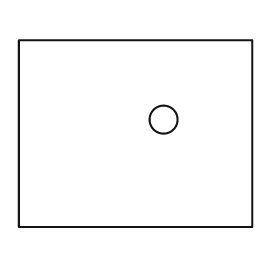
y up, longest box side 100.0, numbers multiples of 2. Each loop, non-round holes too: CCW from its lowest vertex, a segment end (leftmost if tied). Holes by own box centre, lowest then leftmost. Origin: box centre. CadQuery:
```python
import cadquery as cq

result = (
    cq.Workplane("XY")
    .moveTo(-50.0, -40.0)
    .lineTo(50.0, -40.0)
    .lineTo(50.0, 40.0)
    .lineTo(-50.0, 40.0)
    .close()
    .moveTo(12.0, 6.0)
    .circle(6.0)
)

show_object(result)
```